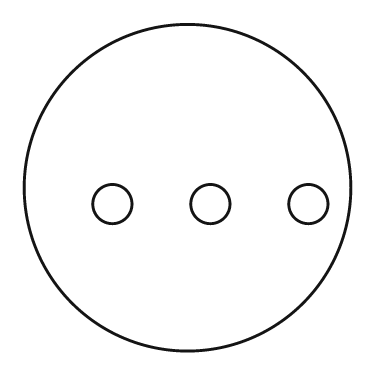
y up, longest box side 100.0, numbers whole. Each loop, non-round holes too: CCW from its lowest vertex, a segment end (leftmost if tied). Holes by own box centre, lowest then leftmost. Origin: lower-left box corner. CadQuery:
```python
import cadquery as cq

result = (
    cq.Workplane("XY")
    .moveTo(50.0, 50.0)
    .circle(50.0)
    .moveTo(27.0, 45.0)
    .circle(6.0)
    .moveTo(57.0, 45.0)
    .circle(6.0)
    .moveTo(87.0, 45.0)
    .circle(6.0)
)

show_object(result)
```